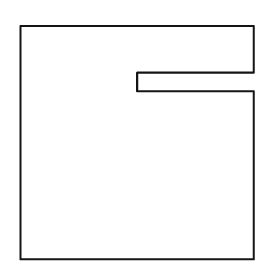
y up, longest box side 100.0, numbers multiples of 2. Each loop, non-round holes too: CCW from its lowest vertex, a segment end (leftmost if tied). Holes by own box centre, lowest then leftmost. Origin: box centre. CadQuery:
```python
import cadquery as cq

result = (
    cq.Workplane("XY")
    .moveTo(-50.0, -50.0)
    .lineTo(50.0, -50.0)
    .lineTo(50.0, 22.0)
    .lineTo(0.0, 22.0)
    .lineTo(0.0, 30.0)
    .lineTo(50.0, 30.0)
    .lineTo(50.0, 50.0)
    .lineTo(-50.0, 50.0)
    .close()
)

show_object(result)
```